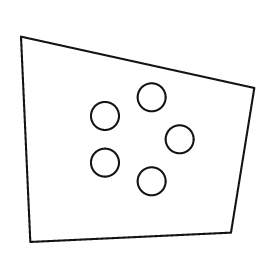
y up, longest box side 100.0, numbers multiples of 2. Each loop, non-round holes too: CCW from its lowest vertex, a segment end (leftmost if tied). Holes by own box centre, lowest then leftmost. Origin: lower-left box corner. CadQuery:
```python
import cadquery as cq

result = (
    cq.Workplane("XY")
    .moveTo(4.0, 0.0)
    .lineTo(90.0, 4.0)
    .lineTo(100.0, 66.0)
    .lineTo(0.0, 88.0)
    .close()
    .moveTo(56.0, 26.0)
    .circle(6.0)
    .moveTo(36.0, 34.0)
    .circle(6.0)
    .moveTo(68.0, 44.0)
    .circle(6.0)
    .moveTo(36.0, 54.0)
    .circle(6.0)
    .moveTo(56.0, 62.0)
    .circle(6.0)
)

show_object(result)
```